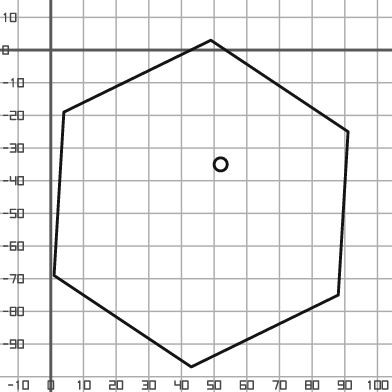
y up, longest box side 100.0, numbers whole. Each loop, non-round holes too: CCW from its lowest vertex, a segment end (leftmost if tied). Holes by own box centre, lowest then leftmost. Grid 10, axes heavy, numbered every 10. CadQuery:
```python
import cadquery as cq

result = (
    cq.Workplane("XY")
    .moveTo(43.0, -97.0)
    .lineTo(88.0, -75.0)
    .lineTo(91.0, -25.0)
    .lineTo(49.0, 3.0)
    .lineTo(4.0, -19.0)
    .lineTo(1.0, -69.0)
    .close()
    .moveTo(52.0, -35.0)
    .circle(2.0)
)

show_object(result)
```